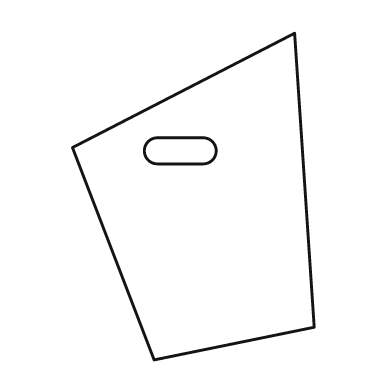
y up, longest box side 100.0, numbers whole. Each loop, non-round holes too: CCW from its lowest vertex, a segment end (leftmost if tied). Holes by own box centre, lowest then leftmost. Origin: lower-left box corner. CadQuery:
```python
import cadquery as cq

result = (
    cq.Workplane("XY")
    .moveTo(25.0, 0.0)
    .lineTo(74.0, 10.0)
    .lineTo(68.0, 100.0)
    .lineTo(0.0, 65.0)
    .close()
    .moveTo(26.0, 60.0)
    .lineTo(40.0, 60.0)
    .threePointArc((44.0, 64.0), (40.0, 68.0))
    .lineTo(26.0, 68.0)
    .threePointArc((22.0, 64.0), (26.0, 60.0))
    .close()
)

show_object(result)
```